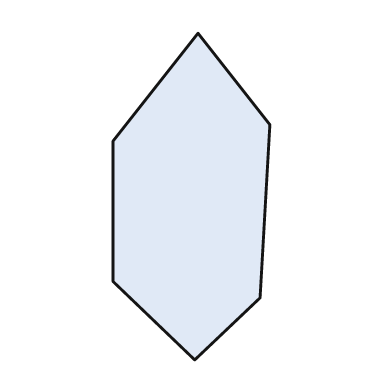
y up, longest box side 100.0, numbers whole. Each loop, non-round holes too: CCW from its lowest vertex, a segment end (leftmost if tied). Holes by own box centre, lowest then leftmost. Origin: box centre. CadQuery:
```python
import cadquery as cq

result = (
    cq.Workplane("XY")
    .moveTo(1.0, -50.0)
    .lineTo(21.0, -31.0)
    .lineTo(24.0, 22.0)
    .lineTo(2.0, 50.0)
    .lineTo(-24.0, 17.0)
    .lineTo(-24.0, -26.0)
    .close()
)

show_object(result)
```